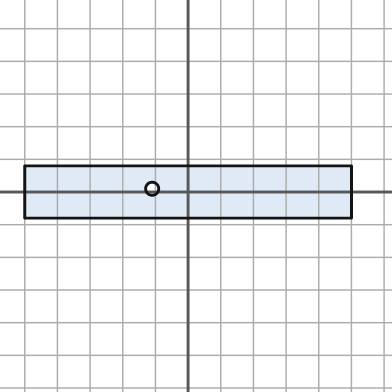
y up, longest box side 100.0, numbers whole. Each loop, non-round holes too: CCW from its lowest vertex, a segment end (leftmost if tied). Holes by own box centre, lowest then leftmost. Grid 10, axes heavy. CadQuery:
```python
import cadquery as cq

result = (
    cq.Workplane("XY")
    .moveTo(-50.0, -8.0)
    .lineTo(50.0, -8.0)
    .lineTo(50.0, 8.0)
    .lineTo(-50.0, 8.0)
    .close()
    .moveTo(-11.0, 1.0)
    .circle(2.0)
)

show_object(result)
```